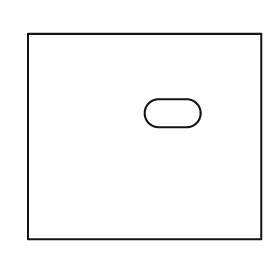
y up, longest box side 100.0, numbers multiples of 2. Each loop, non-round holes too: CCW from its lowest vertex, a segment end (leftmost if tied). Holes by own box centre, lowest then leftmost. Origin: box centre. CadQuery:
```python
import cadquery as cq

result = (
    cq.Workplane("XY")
    .moveTo(-50.0, -44.0)
    .lineTo(50.0, -44.0)
    .lineTo(50.0, 44.0)
    .lineTo(-50.0, 44.0)
    .close()
    .moveTo(6.0, 4.0)
    .lineTo(18.0, 4.0)
    .threePointArc((24.0, 10.0), (18.0, 16.0))
    .lineTo(6.0, 16.0)
    .threePointArc((0.0, 10.0), (6.0, 4.0))
    .close()
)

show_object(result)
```